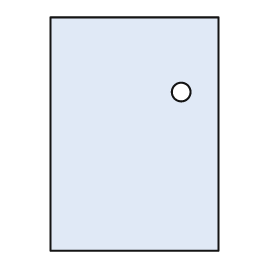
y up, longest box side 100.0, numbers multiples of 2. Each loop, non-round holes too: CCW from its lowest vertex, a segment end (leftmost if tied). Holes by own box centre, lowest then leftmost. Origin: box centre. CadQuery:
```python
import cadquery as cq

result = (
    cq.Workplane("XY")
    .moveTo(-36.0, -50.0)
    .lineTo(36.0, -50.0)
    .lineTo(36.0, 50.0)
    .lineTo(-36.0, 50.0)
    .close()
    .moveTo(20.0, 18.0)
    .circle(4.0)
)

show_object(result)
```